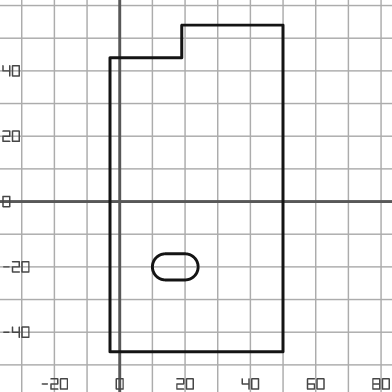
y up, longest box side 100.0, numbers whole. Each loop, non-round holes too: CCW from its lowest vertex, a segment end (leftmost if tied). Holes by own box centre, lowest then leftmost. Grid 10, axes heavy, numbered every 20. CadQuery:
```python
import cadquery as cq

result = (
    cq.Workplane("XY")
    .moveTo(-3.0, -46.0)
    .lineTo(50.0, -46.0)
    .lineTo(50.0, 54.0)
    .lineTo(19.0, 54.0)
    .lineTo(19.0, 44.0)
    .lineTo(-3.0, 44.0)
    .close()
    .moveTo(14.0, -24.0)
    .lineTo(20.0, -24.0)
    .threePointArc((24.0, -20.0), (20.0, -16.0))
    .lineTo(14.0, -16.0)
    .threePointArc((10.0, -20.0), (14.0, -24.0))
    .close()
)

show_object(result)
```